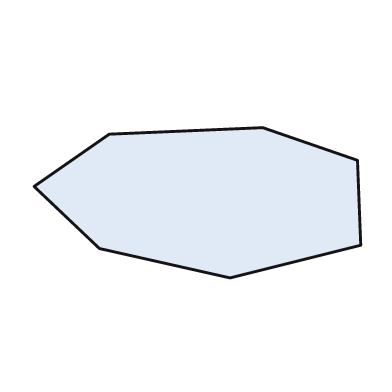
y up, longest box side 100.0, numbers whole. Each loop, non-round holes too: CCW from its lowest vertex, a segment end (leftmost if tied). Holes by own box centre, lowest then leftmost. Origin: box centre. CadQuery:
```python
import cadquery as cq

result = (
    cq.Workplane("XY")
    .moveTo(10.0, -23.0)
    .lineTo(50.0, -13.0)
    .lineTo(49.0, 13.0)
    .lineTo(20.0, 23.0)
    .lineTo(-27.0, 21.0)
    .lineTo(-50.0, 5.0)
    .lineTo(-30.0, -14.0)
    .close()
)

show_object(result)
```